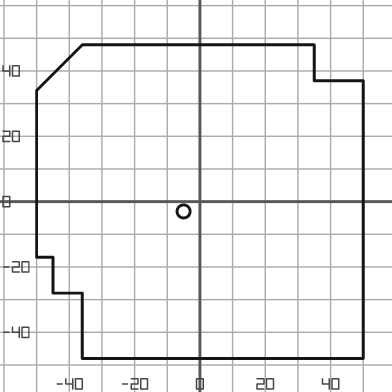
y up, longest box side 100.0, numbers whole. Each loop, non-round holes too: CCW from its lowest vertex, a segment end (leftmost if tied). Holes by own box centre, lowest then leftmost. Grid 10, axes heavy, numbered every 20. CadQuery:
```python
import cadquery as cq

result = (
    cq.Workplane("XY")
    .moveTo(-36.0, -48.0)
    .lineTo(50.0, -48.0)
    .lineTo(50.0, 37.0)
    .lineTo(35.0, 37.0)
    .lineTo(35.0, 48.0)
    .lineTo(-36.0, 48.0)
    .lineTo(-50.0, 34.0)
    .lineTo(-50.0, -17.0)
    .lineTo(-45.0, -17.0)
    .lineTo(-45.0, -28.0)
    .lineTo(-36.0, -28.0)
    .close()
    .moveTo(-5.0, -3.0)
    .circle(2.0)
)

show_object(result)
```